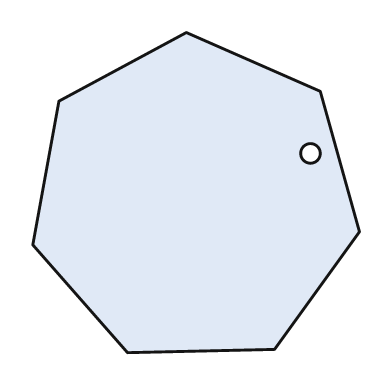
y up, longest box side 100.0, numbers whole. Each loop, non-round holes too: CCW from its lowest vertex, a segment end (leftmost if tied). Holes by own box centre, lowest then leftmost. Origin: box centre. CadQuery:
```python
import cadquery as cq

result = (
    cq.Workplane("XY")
    .moveTo(-21.0, -49.0)
    .lineTo(24.0, -48.0)
    .lineTo(50.0, -12.0)
    .lineTo(38.0, 31.0)
    .lineTo(-3.0, 49.0)
    .lineTo(-42.0, 28.0)
    .lineTo(-50.0, -16.0)
    .close()
    .moveTo(35.0, 12.0)
    .circle(3.0)
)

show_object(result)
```